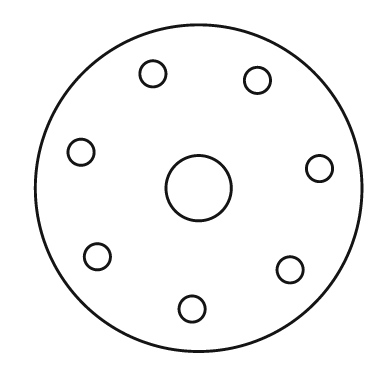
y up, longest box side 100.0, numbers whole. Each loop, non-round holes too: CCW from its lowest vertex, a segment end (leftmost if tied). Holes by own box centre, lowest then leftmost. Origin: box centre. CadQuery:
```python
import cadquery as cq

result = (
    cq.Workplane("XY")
    .moveTo(0.0, 0.0)
    .circle(50.0)
    .moveTo(-2.0, -37.0)
    .circle(4.0)
    .moveTo(28.0, -25.0)
    .circle(4.0)
    .moveTo(-31.0, -21.0)
    .circle(4.0)
    .moveTo(0.0, 0.0)
    .circle(10.0)
    .moveTo(37.0, 6.0)
    .circle(4.0)
    .moveTo(-36.0, 11.0)
    .circle(4.0)
    .moveTo(18.0, 33.0)
    .circle(4.0)
    .moveTo(-14.0, 35.0)
    .circle(4.0)
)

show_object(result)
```